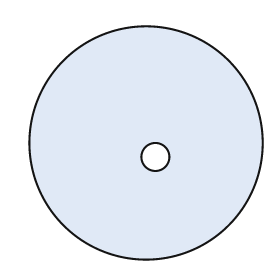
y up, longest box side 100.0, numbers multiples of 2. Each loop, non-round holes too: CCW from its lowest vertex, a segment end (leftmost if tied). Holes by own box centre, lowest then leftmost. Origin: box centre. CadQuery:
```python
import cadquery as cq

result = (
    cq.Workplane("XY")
    .moveTo(0.0, 0.0)
    .circle(50.0)
    .moveTo(4.0, -6.0)
    .circle(6.0)
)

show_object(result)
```